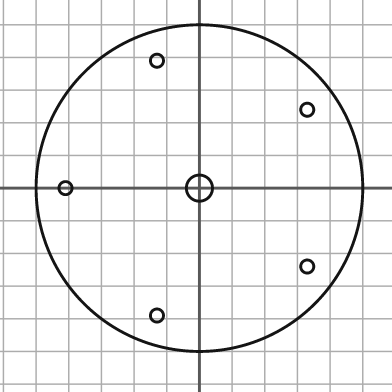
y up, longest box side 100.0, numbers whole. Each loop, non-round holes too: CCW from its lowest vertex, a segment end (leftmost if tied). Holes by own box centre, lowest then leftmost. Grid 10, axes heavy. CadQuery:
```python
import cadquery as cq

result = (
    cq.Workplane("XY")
    .moveTo(0.0, 0.0)
    .circle(50.0)
    .moveTo(-13.0, -39.0)
    .circle(2.0)
    .moveTo(33.0, -24.0)
    .circle(2.0)
    .moveTo(-41.0, 0.0)
    .circle(2.0)
    .moveTo(0.0, 0.0)
    .circle(4.0)
    .moveTo(33.0, 24.0)
    .circle(2.0)
    .moveTo(-13.0, 39.0)
    .circle(2.0)
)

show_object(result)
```